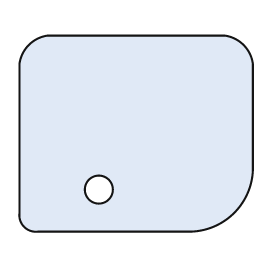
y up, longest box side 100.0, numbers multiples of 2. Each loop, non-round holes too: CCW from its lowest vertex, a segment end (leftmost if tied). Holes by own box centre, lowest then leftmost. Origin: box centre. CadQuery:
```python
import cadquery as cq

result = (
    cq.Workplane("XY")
    .moveTo(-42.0, -42.0)
    .lineTo(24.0, -42.0)
    .threePointArc((42.0, -34.0), (50.0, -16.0))
    .lineTo(50.0, 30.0)
    .threePointArc((46.0, 38.0), (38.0, 42.0))
    .lineTo(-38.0, 42.0)
    .threePointArc((-46.0, 38.0), (-50.0, 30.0))
    .lineTo(-50.0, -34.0)
    .threePointArc((-48.0, -40.0), (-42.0, -42.0))
    .close()
    .moveTo(-16.0, -24.0)
    .circle(6.0)
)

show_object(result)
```